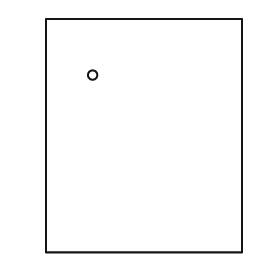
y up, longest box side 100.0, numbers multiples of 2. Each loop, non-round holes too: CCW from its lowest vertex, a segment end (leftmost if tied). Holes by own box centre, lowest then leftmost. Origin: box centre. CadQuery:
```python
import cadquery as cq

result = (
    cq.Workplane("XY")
    .moveTo(-42.0, -50.0)
    .lineTo(42.0, -50.0)
    .lineTo(42.0, 50.0)
    .lineTo(-42.0, 50.0)
    .close()
    .moveTo(-22.0, 26.0)
    .circle(2.0)
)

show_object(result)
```